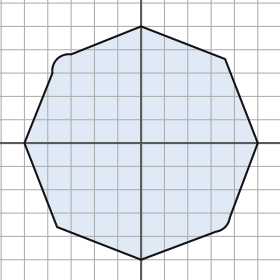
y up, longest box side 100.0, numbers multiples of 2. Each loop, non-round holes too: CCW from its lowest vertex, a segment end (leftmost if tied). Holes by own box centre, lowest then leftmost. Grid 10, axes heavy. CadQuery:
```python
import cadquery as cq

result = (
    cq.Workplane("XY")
    .moveTo(0.0, -50.0)
    .lineTo(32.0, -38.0)
    .threePointArc((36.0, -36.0), (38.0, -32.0))
    .lineTo(50.0, 0.0)
    .lineTo(36.0, 36.0)
    .lineTo(0.0, 50.0)
    .lineTo(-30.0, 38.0)
    .threePointArc((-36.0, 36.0), (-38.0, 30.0))
    .lineTo(-50.0, 0.0)
    .lineTo(-36.0, -36.0)
    .close()
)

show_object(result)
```